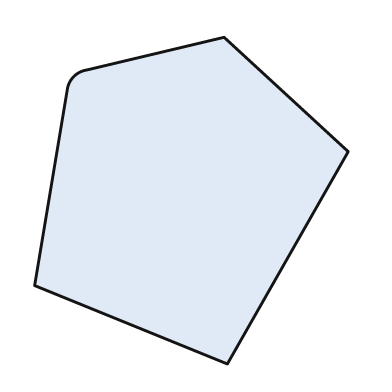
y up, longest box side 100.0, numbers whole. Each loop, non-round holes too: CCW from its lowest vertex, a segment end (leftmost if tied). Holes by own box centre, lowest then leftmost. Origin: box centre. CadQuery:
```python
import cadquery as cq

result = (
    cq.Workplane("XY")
    .moveTo(11.0, -50.0)
    .lineTo(48.0, 15.0)
    .lineTo(10.0, 50.0)
    .lineTo(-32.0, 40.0)
    .threePointArc((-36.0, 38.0), (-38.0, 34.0))
    .lineTo(-48.0, -26.0)
    .close()
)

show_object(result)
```